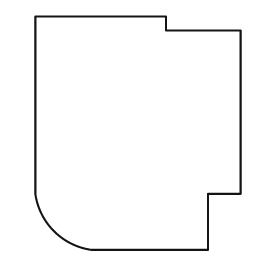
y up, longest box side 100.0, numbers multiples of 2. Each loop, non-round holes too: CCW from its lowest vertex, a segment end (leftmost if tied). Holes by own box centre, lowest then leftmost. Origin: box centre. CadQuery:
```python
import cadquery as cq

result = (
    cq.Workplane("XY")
    .moveTo(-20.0, -50.0)
    .lineTo(30.0, -50.0)
    .lineTo(30.0, -26.0)
    .lineTo(44.0, -26.0)
    .lineTo(44.0, 44.0)
    .lineTo(12.0, 44.0)
    .lineTo(12.0, 50.0)
    .lineTo(-44.0, 50.0)
    .lineTo(-44.0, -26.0)
    .threePointArc((-36.0, -42.0), (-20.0, -50.0))
    .close()
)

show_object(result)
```